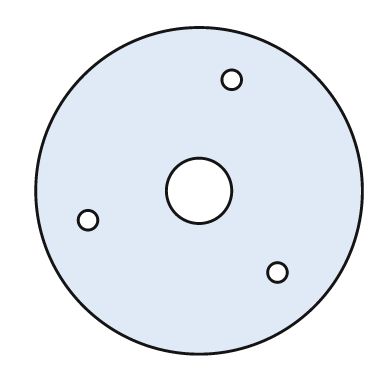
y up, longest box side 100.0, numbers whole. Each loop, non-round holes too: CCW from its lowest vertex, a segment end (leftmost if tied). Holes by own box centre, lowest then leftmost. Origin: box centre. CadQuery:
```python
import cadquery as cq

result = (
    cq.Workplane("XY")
    .moveTo(0.0, 0.0)
    .circle(50.0)
    .moveTo(24.0, -25.0)
    .circle(3.0)
    .moveTo(-34.0, -9.0)
    .circle(3.0)
    .moveTo(0.0, 0.0)
    .circle(10.0)
    .moveTo(10.0, 34.0)
    .circle(3.0)
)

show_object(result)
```